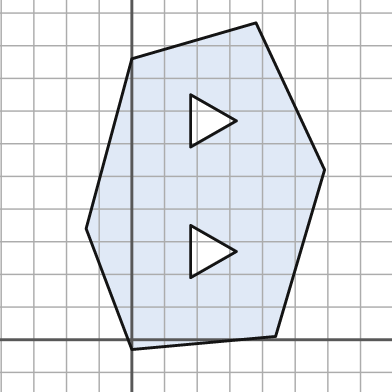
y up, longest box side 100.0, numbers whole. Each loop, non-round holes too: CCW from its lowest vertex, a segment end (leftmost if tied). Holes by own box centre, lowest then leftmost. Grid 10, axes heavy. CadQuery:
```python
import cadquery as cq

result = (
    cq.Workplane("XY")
    .moveTo(0.0, -3.0)
    .lineTo(44.0, 1.0)
    .lineTo(59.0, 52.0)
    .lineTo(38.0, 97.0)
    .lineTo(0.0, 86.0)
    .lineTo(-14.0, 34.0)
    .close()
    .moveTo(18.0, 19.0)
    .lineTo(32.0, 27.0)
    .lineTo(18.0, 35.0)
    .close()
    .moveTo(18.0, 59.0)
    .lineTo(32.0, 67.0)
    .lineTo(18.0, 75.0)
    .close()
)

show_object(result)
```